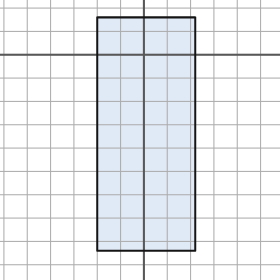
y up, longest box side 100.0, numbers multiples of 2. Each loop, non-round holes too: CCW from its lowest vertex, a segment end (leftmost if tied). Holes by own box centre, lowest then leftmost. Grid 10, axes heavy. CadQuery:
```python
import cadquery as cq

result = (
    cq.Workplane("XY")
    .moveTo(-20.0, -84.0)
    .lineTo(22.0, -84.0)
    .lineTo(22.0, 16.0)
    .lineTo(-20.0, 16.0)
    .close()
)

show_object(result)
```